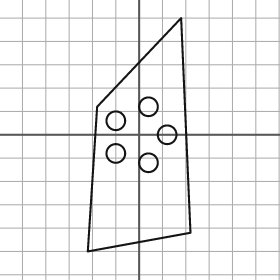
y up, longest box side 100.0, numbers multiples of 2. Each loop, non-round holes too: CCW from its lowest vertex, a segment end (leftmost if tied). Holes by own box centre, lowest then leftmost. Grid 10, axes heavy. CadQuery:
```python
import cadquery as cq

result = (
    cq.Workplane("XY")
    .moveTo(-22.0, -50.0)
    .lineTo(22.0, -42.0)
    .lineTo(18.0, 50.0)
    .lineTo(-18.0, 12.0)
    .close()
    .moveTo(4.0, -12.0)
    .circle(4.0)
    .moveTo(-10.0, -8.0)
    .circle(4.0)
    .moveTo(12.0, 0.0)
    .circle(4.0)
    .moveTo(-10.0, 6.0)
    .circle(4.0)
    .moveTo(4.0, 12.0)
    .circle(4.0)
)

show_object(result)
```